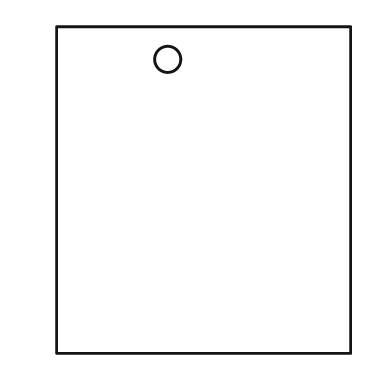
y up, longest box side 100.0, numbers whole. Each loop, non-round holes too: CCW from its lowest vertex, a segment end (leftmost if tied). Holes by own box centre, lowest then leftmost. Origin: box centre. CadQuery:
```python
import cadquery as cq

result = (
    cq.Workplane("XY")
    .moveTo(-45.0, -50.0)
    .lineTo(45.0, -50.0)
    .lineTo(45.0, 50.0)
    .lineTo(-45.0, 50.0)
    .close()
    .moveTo(-11.0, 40.0)
    .circle(4.0)
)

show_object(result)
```